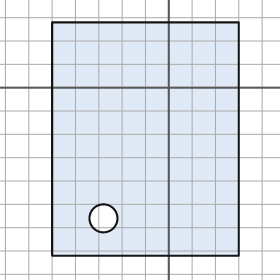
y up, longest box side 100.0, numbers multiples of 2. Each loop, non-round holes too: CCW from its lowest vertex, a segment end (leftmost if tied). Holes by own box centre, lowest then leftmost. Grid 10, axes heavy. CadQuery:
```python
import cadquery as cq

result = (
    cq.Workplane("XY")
    .moveTo(-50.0, -72.0)
    .lineTo(30.0, -72.0)
    .lineTo(30.0, 28.0)
    .lineTo(-50.0, 28.0)
    .close()
    .moveTo(-28.0, -56.0)
    .circle(6.0)
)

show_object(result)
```